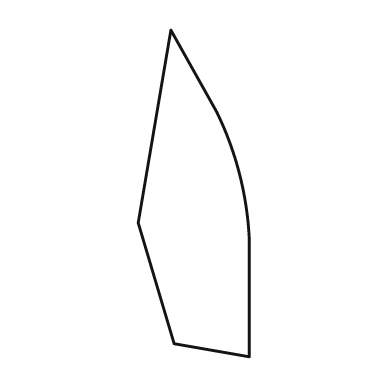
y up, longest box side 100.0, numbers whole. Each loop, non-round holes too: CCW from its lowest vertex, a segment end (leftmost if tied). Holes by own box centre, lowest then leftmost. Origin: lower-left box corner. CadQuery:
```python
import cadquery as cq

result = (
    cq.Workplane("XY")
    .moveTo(34.0, 0.0)
    .lineTo(34.0, 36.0)
    .threePointArc((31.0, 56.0), (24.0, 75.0))
    .lineTo(10.0, 100.0)
    .lineTo(0.0, 41.0)
    .lineTo(11.0, 4.0)
    .close()
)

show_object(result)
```